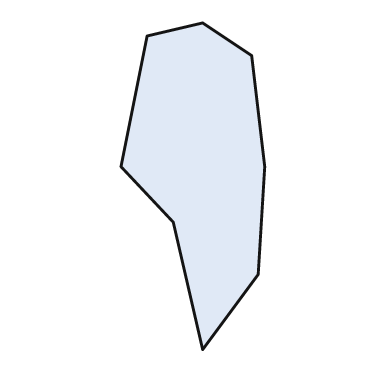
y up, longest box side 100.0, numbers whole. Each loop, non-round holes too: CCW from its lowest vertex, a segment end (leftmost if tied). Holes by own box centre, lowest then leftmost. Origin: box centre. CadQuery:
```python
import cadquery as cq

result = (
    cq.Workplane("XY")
    .moveTo(3.0, -50.0)
    .lineTo(20.0, -27.0)
    .lineTo(22.0, 6.0)
    .lineTo(18.0, 40.0)
    .lineTo(3.0, 50.0)
    .lineTo(-14.0, 46.0)
    .lineTo(-22.0, 6.0)
    .lineTo(-6.0, -11.0)
    .close()
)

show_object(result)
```